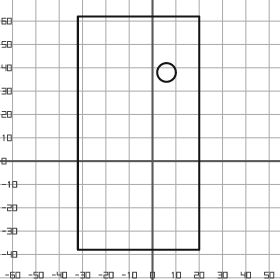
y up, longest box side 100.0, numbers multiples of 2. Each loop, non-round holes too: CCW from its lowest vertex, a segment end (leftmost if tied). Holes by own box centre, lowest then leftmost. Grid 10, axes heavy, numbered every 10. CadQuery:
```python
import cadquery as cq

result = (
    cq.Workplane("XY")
    .moveTo(-32.0, -38.0)
    .lineTo(20.0, -38.0)
    .lineTo(20.0, 62.0)
    .lineTo(-32.0, 62.0)
    .close()
    .moveTo(6.0, 38.0)
    .circle(4.0)
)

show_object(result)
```